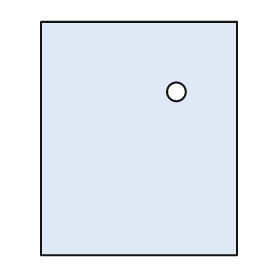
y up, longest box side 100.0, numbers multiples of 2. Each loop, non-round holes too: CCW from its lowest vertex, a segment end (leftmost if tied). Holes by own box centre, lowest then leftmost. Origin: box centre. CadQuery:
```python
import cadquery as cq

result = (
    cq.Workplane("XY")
    .moveTo(-42.0, -50.0)
    .lineTo(42.0, -50.0)
    .lineTo(42.0, 50.0)
    .lineTo(-42.0, 50.0)
    .close()
    .moveTo(16.0, 20.0)
    .circle(4.0)
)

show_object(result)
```